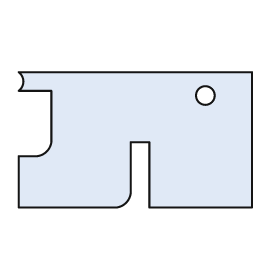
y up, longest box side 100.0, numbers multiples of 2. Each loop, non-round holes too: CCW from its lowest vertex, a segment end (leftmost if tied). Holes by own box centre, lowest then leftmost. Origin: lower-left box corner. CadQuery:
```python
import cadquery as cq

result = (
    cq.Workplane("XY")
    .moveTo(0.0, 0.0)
    .lineTo(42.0, 0.0)
    .threePointArc((46.0, 2.0), (48.0, 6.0))
    .lineTo(48.0, 28.0)
    .lineTo(56.0, 28.0)
    .lineTo(56.0, 0.0)
    .lineTo(100.0, 0.0)
    .lineTo(100.0, 58.0)
    .lineTo(0.0, 58.0)
    .threePointArc((2.0, 54.0), (0.0, 50.0))
    .lineTo(14.0, 50.0)
    .lineTo(14.0, 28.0)
    .threePointArc((12.0, 24.0), (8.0, 22.0))
    .lineTo(0.0, 22.0)
    .close()
    .moveTo(80.0, 48.0)
    .circle(4.0)
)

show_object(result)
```